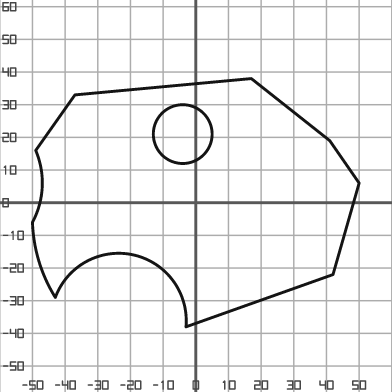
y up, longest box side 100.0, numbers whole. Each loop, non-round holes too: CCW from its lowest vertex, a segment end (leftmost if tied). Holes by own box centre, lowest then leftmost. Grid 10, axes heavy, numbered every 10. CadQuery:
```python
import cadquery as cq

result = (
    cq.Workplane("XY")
    .moveTo(-3.0, -38.0)
    .lineTo(42.0, -22.0)
    .lineTo(50.0, 6.0)
    .lineTo(41.0, 19.0)
    .lineTo(17.0, 38.0)
    .lineTo(-37.0, 33.0)
    .lineTo(-49.0, 16.0)
    .threePointArc((-47.0, 5.0), (-50.0, -6.0))
    .threePointArc((-48.0, -18.0), (-43.0, -29.0))
    .threePointArc((-19.0, -16.0), (-3.0, -38.0))
    .close()
    .moveTo(-4.0, 21.0)
    .circle(9.0)
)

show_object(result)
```